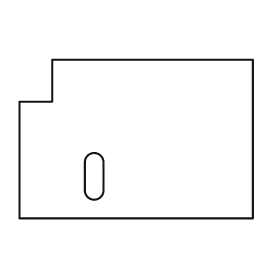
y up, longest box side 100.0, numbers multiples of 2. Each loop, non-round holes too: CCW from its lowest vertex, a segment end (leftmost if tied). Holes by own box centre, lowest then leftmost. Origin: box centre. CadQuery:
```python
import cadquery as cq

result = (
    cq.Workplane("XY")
    .moveTo(-50.0, -34.0)
    .lineTo(50.0, -34.0)
    .lineTo(50.0, 34.0)
    .lineTo(-36.0, 34.0)
    .lineTo(-36.0, 16.0)
    .lineTo(-50.0, 16.0)
    .close()
    .moveTo(-22.0, -22.0)
    .threePointArc((-18.0, -26.0), (-14.0, -22.0))
    .lineTo(-14.0, -10.0)
    .threePointArc((-18.0, -6.0), (-22.0, -10.0))
    .close()
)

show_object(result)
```